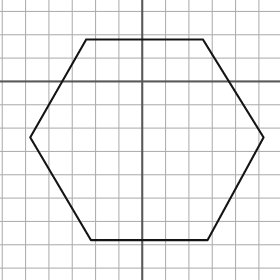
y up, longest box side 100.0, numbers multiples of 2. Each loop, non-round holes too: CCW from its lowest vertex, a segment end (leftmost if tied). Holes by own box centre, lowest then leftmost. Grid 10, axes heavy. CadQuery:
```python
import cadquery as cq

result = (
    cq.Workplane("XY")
    .moveTo(-22.0, -68.0)
    .lineTo(28.0, -68.0)
    .lineTo(52.0, -24.0)
    .lineTo(26.0, 18.0)
    .lineTo(-24.0, 18.0)
    .lineTo(-48.0, -24.0)
    .close()
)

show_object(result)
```